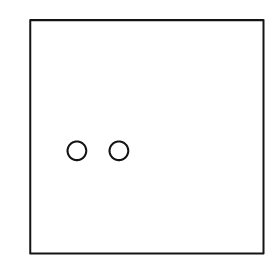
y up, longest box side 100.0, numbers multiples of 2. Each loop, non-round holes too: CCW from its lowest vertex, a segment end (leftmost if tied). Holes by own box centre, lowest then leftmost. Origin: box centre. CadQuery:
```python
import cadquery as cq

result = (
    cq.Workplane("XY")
    .moveTo(-50.0, -50.0)
    .lineTo(50.0, -50.0)
    .lineTo(50.0, 50.0)
    .lineTo(-50.0, 50.0)
    .close()
    .moveTo(-30.0, -6.0)
    .circle(4.0)
    .moveTo(-12.0, -6.0)
    .circle(4.0)
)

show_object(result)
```